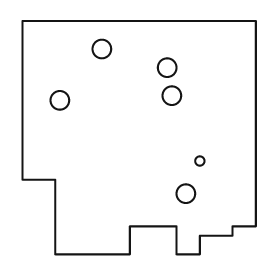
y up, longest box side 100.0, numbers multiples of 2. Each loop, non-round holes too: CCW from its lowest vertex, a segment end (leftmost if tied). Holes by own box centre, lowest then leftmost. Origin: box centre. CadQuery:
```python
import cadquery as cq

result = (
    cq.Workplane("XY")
    .moveTo(-36.0, -50.0)
    .lineTo(-4.0, -50.0)
    .lineTo(-4.0, -38.0)
    .lineTo(16.0, -38.0)
    .lineTo(16.0, -50.0)
    .lineTo(26.0, -50.0)
    .lineTo(26.0, -42.0)
    .lineTo(40.0, -42.0)
    .lineTo(40.0, -38.0)
    .lineTo(50.0, -38.0)
    .lineTo(50.0, 50.0)
    .lineTo(-50.0, 50.0)
    .lineTo(-50.0, -18.0)
    .lineTo(-36.0, -18.0)
    .close()
    .moveTo(20.0, -24.0)
    .circle(4.0)
    .moveTo(26.0, -10.0)
    .circle(2.0)
    .moveTo(-34.0, 16.0)
    .circle(4.0)
    .moveTo(14.0, 18.0)
    .circle(4.0)
    .moveTo(12.0, 30.0)
    .circle(4.0)
    .moveTo(-16.0, 38.0)
    .circle(4.0)
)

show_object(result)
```